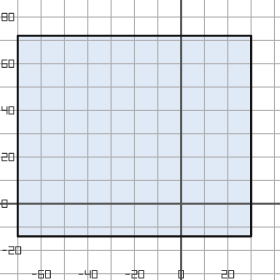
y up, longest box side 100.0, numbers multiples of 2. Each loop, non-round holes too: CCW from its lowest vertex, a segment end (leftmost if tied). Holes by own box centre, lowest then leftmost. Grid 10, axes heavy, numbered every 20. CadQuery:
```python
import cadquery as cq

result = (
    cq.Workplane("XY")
    .moveTo(-70.0, -14.0)
    .lineTo(30.0, -14.0)
    .lineTo(30.0, 72.0)
    .lineTo(-70.0, 72.0)
    .close()
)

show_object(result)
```